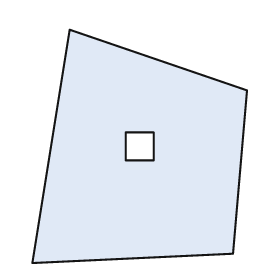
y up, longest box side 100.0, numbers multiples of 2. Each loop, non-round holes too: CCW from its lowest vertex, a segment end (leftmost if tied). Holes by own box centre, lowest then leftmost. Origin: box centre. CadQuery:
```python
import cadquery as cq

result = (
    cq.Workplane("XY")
    .moveTo(-46.0, -50.0)
    .lineTo(40.0, -46.0)
    .lineTo(46.0, 24.0)
    .lineTo(-30.0, 50.0)
    .close()
    .moveTo(-6.0, -6.0)
    .lineTo(6.0, -6.0)
    .lineTo(6.0, 6.0)
    .lineTo(-6.0, 6.0)
    .close()
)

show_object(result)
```